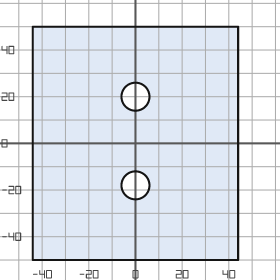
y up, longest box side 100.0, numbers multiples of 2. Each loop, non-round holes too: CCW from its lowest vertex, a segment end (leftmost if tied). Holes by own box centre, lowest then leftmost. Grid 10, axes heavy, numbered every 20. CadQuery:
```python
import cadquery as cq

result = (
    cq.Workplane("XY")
    .moveTo(-44.0, -50.0)
    .lineTo(44.0, -50.0)
    .lineTo(44.0, 50.0)
    .lineTo(-44.0, 50.0)
    .close()
    .moveTo(0.0, -18.0)
    .circle(6.0)
    .moveTo(0.0, 20.0)
    .circle(6.0)
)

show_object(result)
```